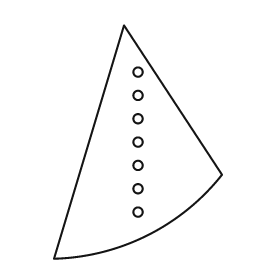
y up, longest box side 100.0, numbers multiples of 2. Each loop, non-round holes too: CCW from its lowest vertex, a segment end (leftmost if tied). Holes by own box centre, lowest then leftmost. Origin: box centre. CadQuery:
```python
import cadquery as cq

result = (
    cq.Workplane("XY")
    .moveTo(-36.0, -50.0)
    .threePointArc((4.0, -40.0), (36.0, -14.0))
    .lineTo(-6.0, 50.0)
    .close()
    .moveTo(0.0, -30.0)
    .circle(2.0)
    .moveTo(0.0, -20.0)
    .circle(2.0)
    .moveTo(0.0, -10.0)
    .circle(2.0)
    .moveTo(0.0, 0.0)
    .circle(2.0)
    .moveTo(0.0, 10.0)
    .circle(2.0)
    .moveTo(0.0, 20.0)
    .circle(2.0)
    .moveTo(0.0, 30.0)
    .circle(2.0)
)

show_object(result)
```